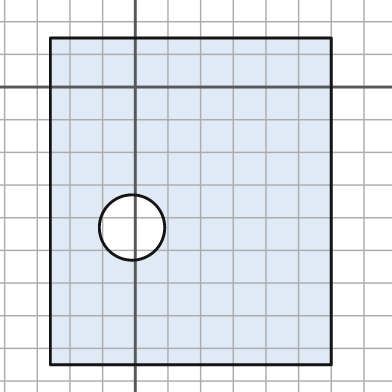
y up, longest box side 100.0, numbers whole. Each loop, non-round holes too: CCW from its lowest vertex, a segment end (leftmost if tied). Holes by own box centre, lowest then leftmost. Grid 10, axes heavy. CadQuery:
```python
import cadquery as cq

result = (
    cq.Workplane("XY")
    .moveTo(-26.0, -85.0)
    .lineTo(60.0, -85.0)
    .lineTo(60.0, 15.0)
    .lineTo(-26.0, 15.0)
    .close()
    .moveTo(-1.0, -43.0)
    .circle(10.0)
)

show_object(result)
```